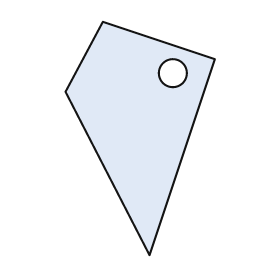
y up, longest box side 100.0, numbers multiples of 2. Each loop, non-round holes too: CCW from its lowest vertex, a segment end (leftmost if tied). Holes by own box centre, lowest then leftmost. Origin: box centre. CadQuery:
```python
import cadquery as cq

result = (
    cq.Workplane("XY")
    .moveTo(4.0, -50.0)
    .lineTo(32.0, 34.0)
    .lineTo(-16.0, 50.0)
    .lineTo(-32.0, 20.0)
    .close()
    .moveTo(14.0, 28.0)
    .circle(6.0)
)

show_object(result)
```